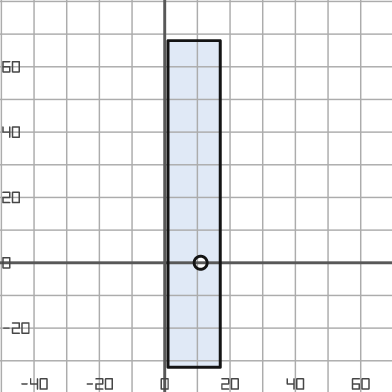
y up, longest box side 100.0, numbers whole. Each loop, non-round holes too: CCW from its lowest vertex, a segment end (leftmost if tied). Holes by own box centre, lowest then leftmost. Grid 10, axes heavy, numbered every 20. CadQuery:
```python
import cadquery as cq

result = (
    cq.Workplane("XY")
    .moveTo(1.0, -32.0)
    .lineTo(17.0, -32.0)
    .lineTo(17.0, 68.0)
    .lineTo(1.0, 68.0)
    .close()
    .moveTo(11.0, 0.0)
    .circle(2.0)
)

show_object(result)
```